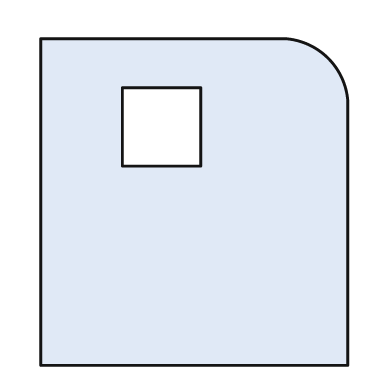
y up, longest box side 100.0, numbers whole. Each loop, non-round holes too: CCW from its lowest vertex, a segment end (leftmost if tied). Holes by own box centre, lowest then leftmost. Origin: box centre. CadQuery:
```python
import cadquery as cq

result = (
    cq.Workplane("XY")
    .moveTo(-47.0, -50.0)
    .lineTo(47.0, -50.0)
    .lineTo(47.0, 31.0)
    .threePointArc((41.0, 44.0), (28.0, 50.0))
    .lineTo(-47.0, 50.0)
    .close()
    .moveTo(-22.0, 11.0)
    .lineTo(2.0, 11.0)
    .lineTo(2.0, 35.0)
    .lineTo(-22.0, 35.0)
    .close()
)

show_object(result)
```